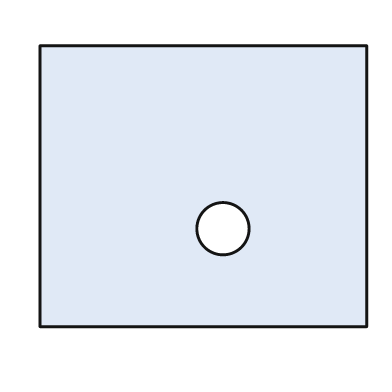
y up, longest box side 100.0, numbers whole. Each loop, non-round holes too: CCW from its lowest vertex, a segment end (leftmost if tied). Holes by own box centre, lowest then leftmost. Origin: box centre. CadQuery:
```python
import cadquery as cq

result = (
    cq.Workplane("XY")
    .moveTo(-50.0, -43.0)
    .lineTo(50.0, -43.0)
    .lineTo(50.0, 43.0)
    .lineTo(-50.0, 43.0)
    .close()
    .moveTo(6.0, -13.0)
    .circle(8.0)
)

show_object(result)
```